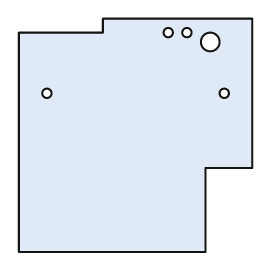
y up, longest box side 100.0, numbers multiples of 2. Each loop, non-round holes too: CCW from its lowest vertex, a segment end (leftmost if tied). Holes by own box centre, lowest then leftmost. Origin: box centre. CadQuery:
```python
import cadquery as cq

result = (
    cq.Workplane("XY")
    .moveTo(-50.0, -50.0)
    .lineTo(30.0, -50.0)
    .lineTo(30.0, -14.0)
    .lineTo(50.0, -14.0)
    .lineTo(50.0, 50.0)
    .lineTo(-14.0, 50.0)
    .lineTo(-14.0, 44.0)
    .lineTo(-50.0, 44.0)
    .close()
    .moveTo(-38.0, 18.0)
    .circle(2.0)
    .moveTo(38.0, 18.0)
    .circle(2.0)
    .moveTo(32.0, 40.0)
    .circle(4.0)
    .moveTo(14.0, 44.0)
    .circle(2.0)
    .moveTo(22.0, 44.0)
    .circle(2.0)
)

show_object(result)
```